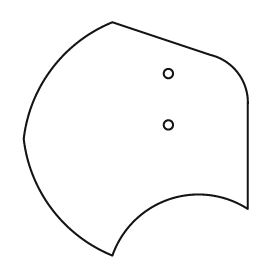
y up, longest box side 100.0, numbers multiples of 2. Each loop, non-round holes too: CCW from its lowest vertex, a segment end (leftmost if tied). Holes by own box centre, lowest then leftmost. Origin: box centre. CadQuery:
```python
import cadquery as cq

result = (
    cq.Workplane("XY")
    .moveTo(-10.0, -50.0)
    .threePointArc((14.0, -26.0), (48.0, -30.0))
    .lineTo(48.0, 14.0)
    .threePointArc((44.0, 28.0), (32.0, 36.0))
    .lineTo(-10.0, 50.0)
    .threePointArc((-36.0, 30.0), (-48.0, 0.0))
    .threePointArc((-36.0, -30.0), (-10.0, -50.0))
    .close()
    .moveTo(14.0, 6.0)
    .circle(2.0)
    .moveTo(14.0, 28.0)
    .circle(2.0)
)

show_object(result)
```